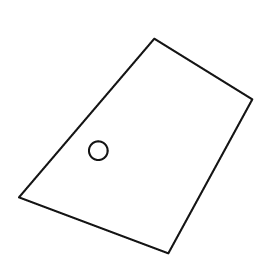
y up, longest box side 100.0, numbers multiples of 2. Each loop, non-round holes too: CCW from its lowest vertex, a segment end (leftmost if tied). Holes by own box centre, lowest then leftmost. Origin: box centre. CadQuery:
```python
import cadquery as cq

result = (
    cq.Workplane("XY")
    .moveTo(14.0, -46.0)
    .lineTo(50.0, 20.0)
    .lineTo(8.0, 46.0)
    .lineTo(-50.0, -22.0)
    .close()
    .moveTo(-16.0, -2.0)
    .circle(4.0)
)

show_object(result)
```